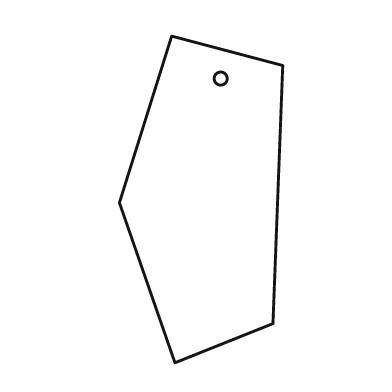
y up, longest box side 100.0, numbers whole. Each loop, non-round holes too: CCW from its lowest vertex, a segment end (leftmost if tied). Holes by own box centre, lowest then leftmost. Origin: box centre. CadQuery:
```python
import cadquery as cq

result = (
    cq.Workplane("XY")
    .moveTo(-8.0, -50.0)
    .lineTo(22.0, -38.0)
    .lineTo(25.0, 41.0)
    .lineTo(-9.0, 50.0)
    .lineTo(-25.0, -1.0)
    .close()
    .moveTo(6.0, 37.0)
    .circle(2.0)
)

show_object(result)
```